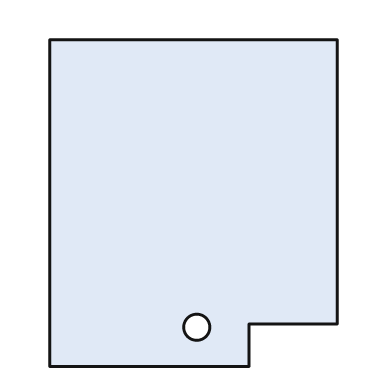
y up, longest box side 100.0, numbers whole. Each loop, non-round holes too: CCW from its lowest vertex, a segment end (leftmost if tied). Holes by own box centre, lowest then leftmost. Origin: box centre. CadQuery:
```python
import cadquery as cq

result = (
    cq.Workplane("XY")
    .moveTo(-44.0, -50.0)
    .lineTo(17.0, -50.0)
    .lineTo(17.0, -37.0)
    .lineTo(44.0, -37.0)
    .lineTo(44.0, 50.0)
    .lineTo(-44.0, 50.0)
    .close()
    .moveTo(1.0, -38.0)
    .circle(4.0)
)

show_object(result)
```